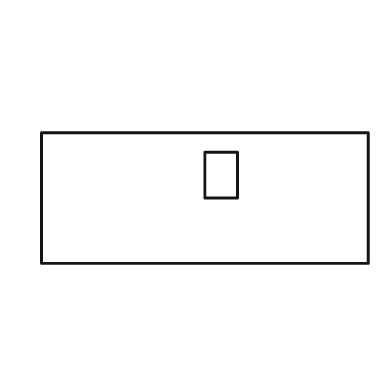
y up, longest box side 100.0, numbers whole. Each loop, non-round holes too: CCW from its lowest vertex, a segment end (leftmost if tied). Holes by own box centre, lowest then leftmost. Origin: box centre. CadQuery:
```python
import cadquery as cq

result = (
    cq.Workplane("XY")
    .moveTo(-50.0, -20.0)
    .lineTo(50.0, -20.0)
    .lineTo(50.0, 20.0)
    .lineTo(-50.0, 20.0)
    .close()
    .moveTo(0.0, 0.0)
    .lineTo(10.0, 0.0)
    .lineTo(10.0, 14.0)
    .lineTo(0.0, 14.0)
    .close()
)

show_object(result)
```